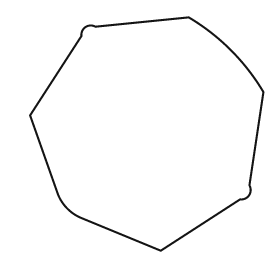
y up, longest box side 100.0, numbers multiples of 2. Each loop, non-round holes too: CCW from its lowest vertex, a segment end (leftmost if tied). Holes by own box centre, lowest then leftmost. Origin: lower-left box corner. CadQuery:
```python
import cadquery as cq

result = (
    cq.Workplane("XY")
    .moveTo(56.0, 0.0)
    .lineTo(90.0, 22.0)
    .threePointArc((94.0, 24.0), (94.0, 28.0))
    .lineTo(100.0, 68.0)
    .threePointArc((86.0, 86.0), (68.0, 100.0))
    .lineTo(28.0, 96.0)
    .threePointArc((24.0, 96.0), (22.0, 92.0))
    .lineTo(0.0, 58.0)
    .lineTo(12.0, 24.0)
    .threePointArc((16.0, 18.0), (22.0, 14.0))
    .close()
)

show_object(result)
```